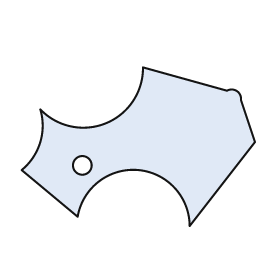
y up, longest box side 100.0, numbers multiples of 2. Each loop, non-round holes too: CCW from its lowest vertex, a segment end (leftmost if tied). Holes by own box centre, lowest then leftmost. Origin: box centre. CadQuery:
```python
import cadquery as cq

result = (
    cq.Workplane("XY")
    .moveTo(22.0, -34.0)
    .lineTo(50.0, 2.0)
    .lineTo(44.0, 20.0)
    .threePointArc((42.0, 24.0), (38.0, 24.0))
    .lineTo(2.0, 34.0)
    .threePointArc((-14.0, 10.0), (-42.0, 16.0))
    .threePointArc((-42.0, 2.0), (-50.0, -10.0))
    .lineTo(-26.0, -30.0)
    .threePointArc((0.0, -10.0), (22.0, -34.0))
    .close()
    .moveTo(-24.0, -8.0)
    .circle(4.0)
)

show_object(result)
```